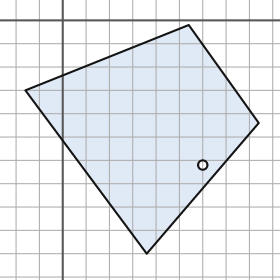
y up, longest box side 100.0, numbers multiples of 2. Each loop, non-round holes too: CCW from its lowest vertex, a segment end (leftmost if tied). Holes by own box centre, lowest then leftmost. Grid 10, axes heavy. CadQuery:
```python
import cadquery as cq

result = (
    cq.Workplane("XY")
    .moveTo(36.0, -100.0)
    .lineTo(84.0, -44.0)
    .lineTo(54.0, -2.0)
    .lineTo(-16.0, -30.0)
    .close()
    .moveTo(60.0, -62.0)
    .circle(2.0)
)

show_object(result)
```